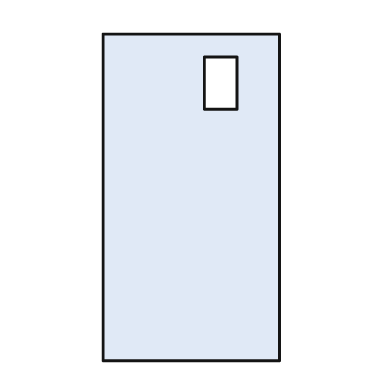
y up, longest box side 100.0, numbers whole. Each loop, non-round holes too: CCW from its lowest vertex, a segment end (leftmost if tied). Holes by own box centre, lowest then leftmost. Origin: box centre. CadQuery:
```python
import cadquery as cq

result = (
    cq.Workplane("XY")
    .moveTo(-27.0, -50.0)
    .lineTo(27.0, -50.0)
    .lineTo(27.0, 50.0)
    .lineTo(-27.0, 50.0)
    .close()
    .moveTo(4.0, 27.0)
    .lineTo(14.0, 27.0)
    .lineTo(14.0, 43.0)
    .lineTo(4.0, 43.0)
    .close()
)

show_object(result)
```